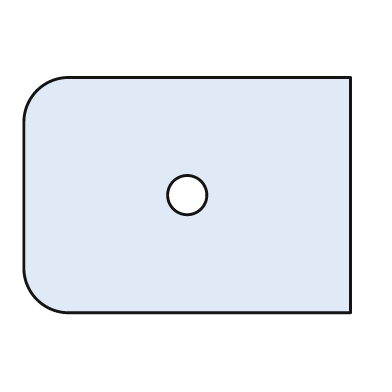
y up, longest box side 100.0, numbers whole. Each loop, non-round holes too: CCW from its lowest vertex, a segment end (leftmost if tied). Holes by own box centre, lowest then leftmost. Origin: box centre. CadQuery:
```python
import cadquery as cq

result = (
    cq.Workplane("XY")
    .moveTo(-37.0, -36.0)
    .lineTo(50.0, -36.0)
    .lineTo(50.0, 36.0)
    .lineTo(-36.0, 36.0)
    .threePointArc((-46.0, 32.0), (-50.0, 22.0))
    .lineTo(-50.0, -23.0)
    .threePointArc((-46.0, -32.0), (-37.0, -36.0))
    .close()
    .moveTo(0.0, 0.0)
    .circle(6.0)
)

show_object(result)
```